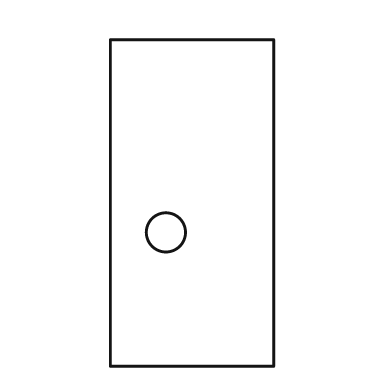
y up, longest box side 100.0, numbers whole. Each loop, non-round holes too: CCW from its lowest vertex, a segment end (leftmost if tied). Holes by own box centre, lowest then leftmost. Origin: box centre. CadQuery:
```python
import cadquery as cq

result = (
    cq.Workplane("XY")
    .moveTo(-25.0, -50.0)
    .lineTo(25.0, -50.0)
    .lineTo(25.0, 50.0)
    .lineTo(-25.0, 50.0)
    .close()
    .moveTo(-8.0, -9.0)
    .circle(6.0)
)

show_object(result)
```